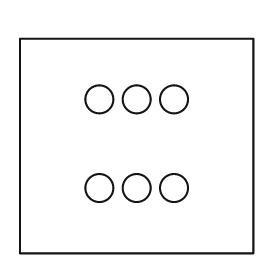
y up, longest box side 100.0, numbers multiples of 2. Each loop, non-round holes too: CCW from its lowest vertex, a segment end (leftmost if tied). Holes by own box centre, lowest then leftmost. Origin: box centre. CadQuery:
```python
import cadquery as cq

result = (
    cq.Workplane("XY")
    .moveTo(-50.0, -46.0)
    .lineTo(50.0, -46.0)
    .lineTo(50.0, 46.0)
    .lineTo(-50.0, 46.0)
    .close()
    .moveTo(-16.0, -18.0)
    .circle(6.0)
    .moveTo(0.0, -18.0)
    .circle(6.0)
    .moveTo(16.0, -18.0)
    .circle(6.0)
    .moveTo(-16.0, 20.0)
    .circle(6.0)
    .moveTo(0.0, 20.0)
    .circle(6.0)
    .moveTo(16.0, 20.0)
    .circle(6.0)
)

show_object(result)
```